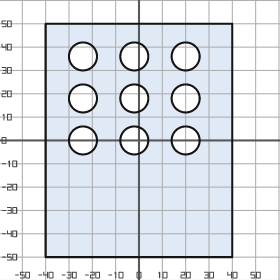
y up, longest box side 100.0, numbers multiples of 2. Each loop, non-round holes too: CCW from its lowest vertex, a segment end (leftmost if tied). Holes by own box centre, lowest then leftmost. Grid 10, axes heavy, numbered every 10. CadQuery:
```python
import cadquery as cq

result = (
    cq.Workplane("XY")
    .moveTo(-40.0, -50.0)
    .lineTo(40.0, -50.0)
    .lineTo(40.0, 50.0)
    .lineTo(-40.0, 50.0)
    .close()
    .moveTo(-24.0, 0.0)
    .circle(6.0)
    .moveTo(-2.0, 0.0)
    .circle(6.0)
    .moveTo(20.0, 0.0)
    .circle(6.0)
    .moveTo(-24.0, 18.0)
    .circle(6.0)
    .moveTo(-2.0, 18.0)
    .circle(6.0)
    .moveTo(20.0, 18.0)
    .circle(6.0)
    .moveTo(-24.0, 36.0)
    .circle(6.0)
    .moveTo(-2.0, 36.0)
    .circle(6.0)
    .moveTo(20.0, 36.0)
    .circle(6.0)
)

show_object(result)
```